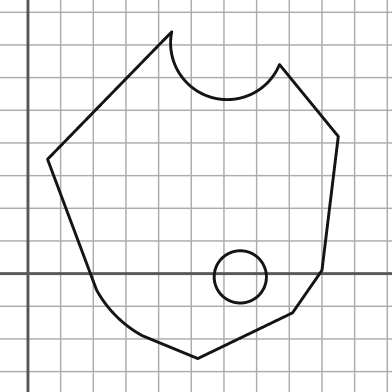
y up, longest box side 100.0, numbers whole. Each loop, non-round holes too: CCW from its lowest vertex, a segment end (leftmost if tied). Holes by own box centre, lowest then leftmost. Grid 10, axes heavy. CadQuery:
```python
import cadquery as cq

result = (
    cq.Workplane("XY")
    .moveTo(52.0, -26.0)
    .lineTo(81.0, -12.0)
    .lineTo(90.0, 1.0)
    .lineTo(95.0, 42.0)
    .lineTo(77.0, 64.0)
    .threePointArc((56.0, 54.0), (44.0, 74.0))
    .lineTo(6.0, 35.0)
    .lineTo(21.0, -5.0)
    .threePointArc((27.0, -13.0), (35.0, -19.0))
    .close()
    .moveTo(65.0, -1.0)
    .circle(8.0)
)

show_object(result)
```